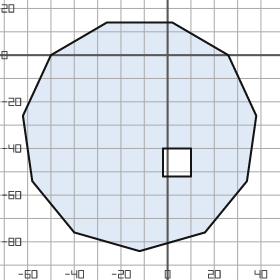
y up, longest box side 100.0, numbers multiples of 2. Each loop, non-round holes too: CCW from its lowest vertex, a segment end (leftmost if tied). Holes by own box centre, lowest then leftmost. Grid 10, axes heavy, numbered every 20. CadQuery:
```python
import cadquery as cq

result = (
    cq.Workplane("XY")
    .moveTo(-12.0, -84.0)
    .lineTo(16.0, -76.0)
    .lineTo(34.0, -54.0)
    .lineTo(38.0, -26.0)
    .lineTo(26.0, 0.0)
    .lineTo(2.0, 14.0)
    .lineTo(-26.0, 14.0)
    .lineTo(-50.0, 0.0)
    .lineTo(-62.0, -26.0)
    .lineTo(-58.0, -54.0)
    .lineTo(-40.0, -76.0)
    .close()
    .moveTo(-2.0, -52.0)
    .lineTo(10.0, -52.0)
    .lineTo(10.0, -40.0)
    .lineTo(-2.0, -40.0)
    .close()
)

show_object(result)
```